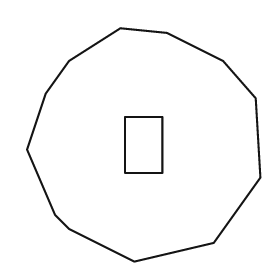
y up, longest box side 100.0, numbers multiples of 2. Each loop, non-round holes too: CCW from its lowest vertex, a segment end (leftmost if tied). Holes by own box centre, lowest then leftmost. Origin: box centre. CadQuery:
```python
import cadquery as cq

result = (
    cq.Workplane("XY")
    .moveTo(-4.0, -50.0)
    .lineTo(30.0, -42.0)
    .lineTo(50.0, -14.0)
    .lineTo(48.0, 20.0)
    .lineTo(34.0, 36.0)
    .lineTo(10.0, 48.0)
    .lineTo(-10.0, 50.0)
    .lineTo(-32.0, 36.0)
    .lineTo(-42.0, 22.0)
    .lineTo(-50.0, -2.0)
    .lineTo(-38.0, -30.0)
    .lineTo(-32.0, -36.0)
    .close()
    .moveTo(-8.0, -12.0)
    .lineTo(8.0, -12.0)
    .lineTo(8.0, 12.0)
    .lineTo(-8.0, 12.0)
    .close()
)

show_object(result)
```